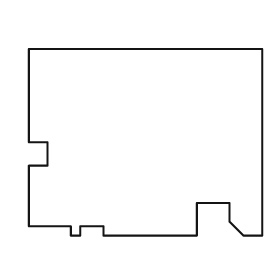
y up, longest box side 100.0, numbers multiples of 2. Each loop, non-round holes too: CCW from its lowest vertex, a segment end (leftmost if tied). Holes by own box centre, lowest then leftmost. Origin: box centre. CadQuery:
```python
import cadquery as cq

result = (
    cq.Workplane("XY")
    .moveTo(-32.0, -40.0)
    .lineTo(-28.0, -40.0)
    .lineTo(-28.0, -36.0)
    .lineTo(-18.0, -36.0)
    .lineTo(-18.0, -40.0)
    .lineTo(22.0, -40.0)
    .lineTo(22.0, -26.0)
    .lineTo(36.0, -26.0)
    .lineTo(36.0, -34.0)
    .lineTo(42.0, -40.0)
    .lineTo(50.0, -40.0)
    .lineTo(50.0, 40.0)
    .lineTo(-50.0, 40.0)
    .lineTo(-50.0, 0.0)
    .lineTo(-42.0, 0.0)
    .lineTo(-42.0, -10.0)
    .lineTo(-50.0, -10.0)
    .lineTo(-50.0, -36.0)
    .lineTo(-32.0, -36.0)
    .close()
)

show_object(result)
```